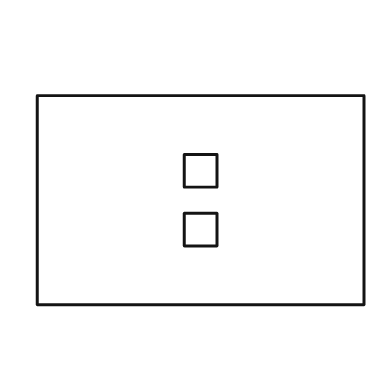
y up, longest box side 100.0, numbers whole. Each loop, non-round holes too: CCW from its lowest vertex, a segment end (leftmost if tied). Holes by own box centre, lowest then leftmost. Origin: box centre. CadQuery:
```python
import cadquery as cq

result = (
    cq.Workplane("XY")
    .moveTo(-50.0, -32.0)
    .lineTo(50.0, -32.0)
    .lineTo(50.0, 32.0)
    .lineTo(-50.0, 32.0)
    .close()
    .moveTo(-5.0, -14.0)
    .lineTo(5.0, -14.0)
    .lineTo(5.0, -4.0)
    .lineTo(-5.0, -4.0)
    .close()
    .moveTo(-5.0, 4.0)
    .lineTo(5.0, 4.0)
    .lineTo(5.0, 14.0)
    .lineTo(-5.0, 14.0)
    .close()
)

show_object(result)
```